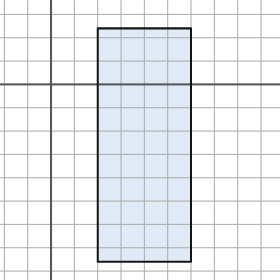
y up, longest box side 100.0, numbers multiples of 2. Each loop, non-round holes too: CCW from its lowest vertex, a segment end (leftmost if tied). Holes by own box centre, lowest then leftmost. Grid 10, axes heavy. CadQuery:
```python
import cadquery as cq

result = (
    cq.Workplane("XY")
    .moveTo(20.0, -76.0)
    .lineTo(60.0, -76.0)
    .lineTo(60.0, 24.0)
    .lineTo(20.0, 24.0)
    .close()
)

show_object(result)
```